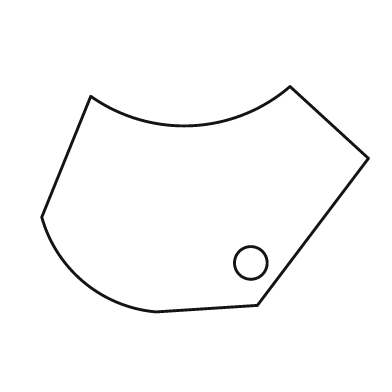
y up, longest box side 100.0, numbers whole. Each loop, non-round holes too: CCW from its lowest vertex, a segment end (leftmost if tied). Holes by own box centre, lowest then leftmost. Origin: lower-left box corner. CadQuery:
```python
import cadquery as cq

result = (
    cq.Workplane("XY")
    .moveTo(35.0, 0.0)
    .lineTo(66.0, 2.0)
    .lineTo(100.0, 47.0)
    .lineTo(76.0, 69.0)
    .threePointArc((46.0, 57.0), (15.0, 66.0))
    .lineTo(0.0, 29.0)
    .threePointArc((13.0, 9.0), (35.0, 0.0))
    .close()
    .moveTo(64.0, 15.0)
    .circle(5.0)
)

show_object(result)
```